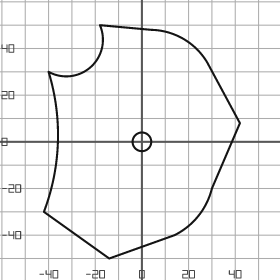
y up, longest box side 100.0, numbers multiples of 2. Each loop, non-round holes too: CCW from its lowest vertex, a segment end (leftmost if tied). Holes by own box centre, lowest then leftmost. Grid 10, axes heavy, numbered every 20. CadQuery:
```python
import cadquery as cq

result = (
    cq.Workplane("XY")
    .moveTo(-14.0, -50.0)
    .lineTo(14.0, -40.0)
    .threePointArc((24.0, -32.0), (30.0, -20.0))
    .lineTo(42.0, 8.0)
    .lineTo(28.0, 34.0)
    .threePointArc((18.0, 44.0), (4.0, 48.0))
    .lineTo(-18.0, 50.0)
    .threePointArc((-22.0, 32.0), (-40.0, 30.0))
    .threePointArc((-36.0, 0.0), (-42.0, -30.0))
    .close()
    .moveTo(0.0, 0.0)
    .circle(4.0)
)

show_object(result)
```